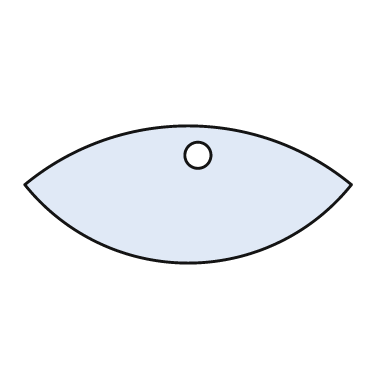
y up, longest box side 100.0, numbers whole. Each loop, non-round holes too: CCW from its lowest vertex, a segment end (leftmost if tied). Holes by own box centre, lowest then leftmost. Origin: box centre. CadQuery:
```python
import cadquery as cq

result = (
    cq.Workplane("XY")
    .moveTo(-50.0, 3.0)
    .threePointArc((0.0, -21.0), (50.0, 3.0))
    .threePointArc((0.0, 21.0), (-50.0, 3.0))
    .close()
    .moveTo(3.0, 12.0)
    .circle(4.0)
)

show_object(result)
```